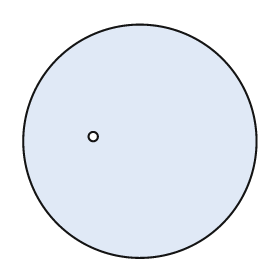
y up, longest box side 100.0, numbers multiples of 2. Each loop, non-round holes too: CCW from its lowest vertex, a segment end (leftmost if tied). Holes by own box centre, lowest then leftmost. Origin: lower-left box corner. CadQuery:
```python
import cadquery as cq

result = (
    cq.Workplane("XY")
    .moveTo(50.0, 50.0)
    .circle(50.0)
    .moveTo(30.0, 52.0)
    .circle(2.0)
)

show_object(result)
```